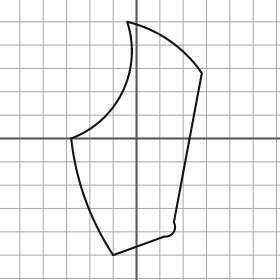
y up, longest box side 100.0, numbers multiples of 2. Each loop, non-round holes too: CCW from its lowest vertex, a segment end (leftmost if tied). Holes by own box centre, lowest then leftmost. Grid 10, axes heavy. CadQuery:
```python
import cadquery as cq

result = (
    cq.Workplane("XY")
    .moveTo(-10.0, -50.0)
    .lineTo(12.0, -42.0)
    .threePointArc((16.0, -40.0), (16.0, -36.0))
    .lineTo(28.0, 28.0)
    .threePointArc((14.0, 42.0), (-4.0, 50.0))
    .threePointArc((-6.0, 20.0), (-28.0, 0.0))
    .threePointArc((-22.0, -26.0), (-10.0, -50.0))
    .close()
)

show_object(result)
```